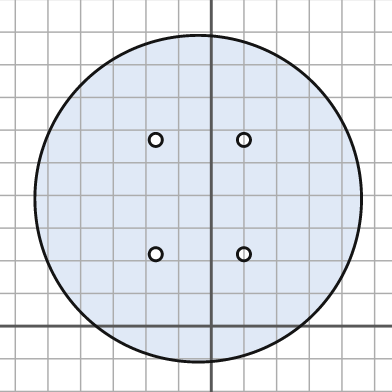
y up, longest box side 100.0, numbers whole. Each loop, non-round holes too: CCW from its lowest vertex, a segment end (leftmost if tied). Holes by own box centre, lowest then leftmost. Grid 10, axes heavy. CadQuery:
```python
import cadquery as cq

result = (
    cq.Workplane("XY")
    .moveTo(-4.0, 39.0)
    .circle(50.0)
    .moveTo(-17.0, 22.0)
    .circle(2.0)
    .moveTo(10.0, 22.0)
    .circle(2.0)
    .moveTo(-17.0, 57.0)
    .circle(2.0)
    .moveTo(10.0, 57.0)
    .circle(2.0)
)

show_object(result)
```